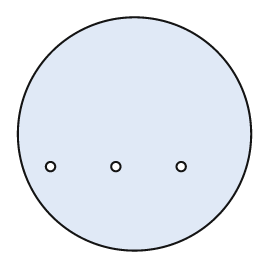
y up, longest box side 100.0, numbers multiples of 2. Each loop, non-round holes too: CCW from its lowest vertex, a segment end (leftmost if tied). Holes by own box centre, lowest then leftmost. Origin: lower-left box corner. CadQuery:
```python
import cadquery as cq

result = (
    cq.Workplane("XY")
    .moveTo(50.0, 50.0)
    .circle(50.0)
    .moveTo(14.0, 36.0)
    .circle(2.0)
    .moveTo(42.0, 36.0)
    .circle(2.0)
    .moveTo(70.0, 36.0)
    .circle(2.0)
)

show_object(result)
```